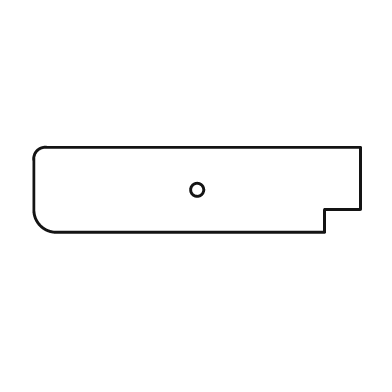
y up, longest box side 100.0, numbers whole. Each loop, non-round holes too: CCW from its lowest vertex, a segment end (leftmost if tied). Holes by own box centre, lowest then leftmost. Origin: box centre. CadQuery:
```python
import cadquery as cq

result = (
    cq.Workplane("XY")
    .moveTo(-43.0, -13.0)
    .lineTo(39.0, -13.0)
    .lineTo(39.0, -6.0)
    .lineTo(50.0, -6.0)
    .lineTo(50.0, 13.0)
    .lineTo(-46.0, 13.0)
    .threePointArc((-49.0, 12.0), (-50.0, 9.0))
    .lineTo(-50.0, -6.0)
    .threePointArc((-48.0, -11.0), (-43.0, -13.0))
    .close()
    .moveTo(0.0, 0.0)
    .circle(2.0)
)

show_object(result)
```